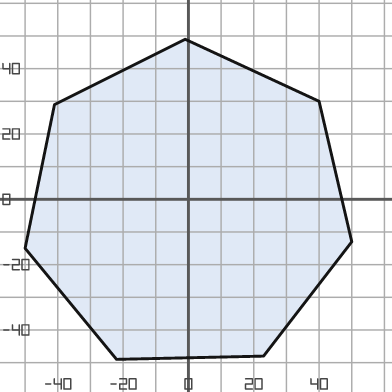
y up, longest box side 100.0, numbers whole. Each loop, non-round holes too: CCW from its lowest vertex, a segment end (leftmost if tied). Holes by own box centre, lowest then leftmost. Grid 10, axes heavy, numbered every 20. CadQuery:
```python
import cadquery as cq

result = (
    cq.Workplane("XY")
    .moveTo(-22.0, -49.0)
    .lineTo(23.0, -48.0)
    .lineTo(50.0, -13.0)
    .lineTo(40.0, 30.0)
    .lineTo(-1.0, 49.0)
    .lineTo(-41.0, 29.0)
    .lineTo(-50.0, -15.0)
    .close()
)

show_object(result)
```